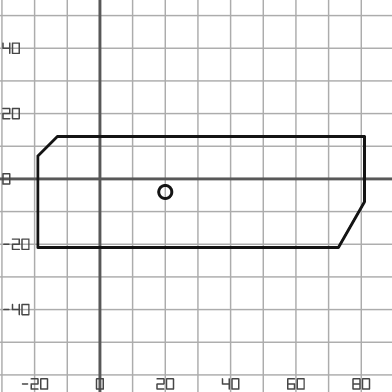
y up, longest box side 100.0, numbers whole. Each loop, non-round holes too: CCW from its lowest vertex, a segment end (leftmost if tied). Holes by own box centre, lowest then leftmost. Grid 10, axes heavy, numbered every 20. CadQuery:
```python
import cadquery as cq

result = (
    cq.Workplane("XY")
    .moveTo(-19.0, -21.0)
    .lineTo(73.0, -21.0)
    .lineTo(81.0, -7.0)
    .lineTo(81.0, 13.0)
    .lineTo(-13.0, 13.0)
    .lineTo(-19.0, 7.0)
    .close()
    .moveTo(20.0, -4.0)
    .circle(2.0)
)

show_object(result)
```